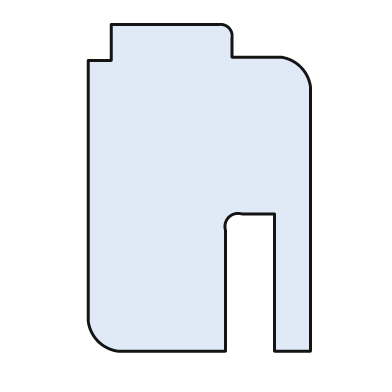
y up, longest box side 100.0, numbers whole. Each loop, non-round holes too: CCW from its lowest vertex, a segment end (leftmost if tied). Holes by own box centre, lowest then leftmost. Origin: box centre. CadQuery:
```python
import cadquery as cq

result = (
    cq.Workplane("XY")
    .moveTo(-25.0, -50.0)
    .lineTo(8.0, -50.0)
    .lineTo(8.0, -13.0)
    .threePointArc((9.0, -9.0), (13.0, -8.0))
    .lineTo(23.0, -8.0)
    .lineTo(23.0, -50.0)
    .lineTo(34.0, -50.0)
    .lineTo(34.0, 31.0)
    .threePointArc((31.0, 37.0), (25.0, 40.0))
    .lineTo(10.0, 40.0)
    .lineTo(10.0, 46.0)
    .threePointArc((9.0, 49.0), (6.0, 50.0))
    .lineTo(-27.0, 50.0)
    .lineTo(-27.0, 39.0)
    .lineTo(-34.0, 39.0)
    .lineTo(-34.0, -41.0)
    .threePointArc((-31.0, -47.0), (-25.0, -50.0))
    .close()
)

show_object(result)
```